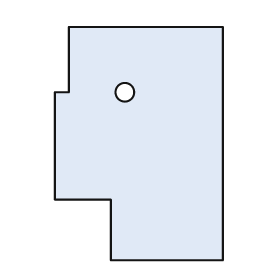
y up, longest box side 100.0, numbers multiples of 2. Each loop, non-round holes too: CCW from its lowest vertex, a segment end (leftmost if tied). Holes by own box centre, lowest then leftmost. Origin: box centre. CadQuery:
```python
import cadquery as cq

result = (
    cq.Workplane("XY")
    .moveTo(-12.0, -50.0)
    .lineTo(36.0, -50.0)
    .lineTo(36.0, 50.0)
    .lineTo(-30.0, 50.0)
    .lineTo(-30.0, 22.0)
    .lineTo(-36.0, 22.0)
    .lineTo(-36.0, -24.0)
    .lineTo(-12.0, -24.0)
    .close()
    .moveTo(-6.0, 22.0)
    .circle(4.0)
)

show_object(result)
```